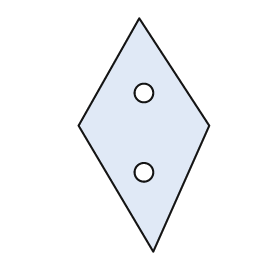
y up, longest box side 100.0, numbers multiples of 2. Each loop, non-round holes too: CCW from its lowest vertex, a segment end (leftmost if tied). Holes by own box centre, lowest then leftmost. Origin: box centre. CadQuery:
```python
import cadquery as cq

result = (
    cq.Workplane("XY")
    .moveTo(4.0, -50.0)
    .lineTo(28.0, 4.0)
    .lineTo(-2.0, 50.0)
    .lineTo(-28.0, 4.0)
    .close()
    .moveTo(0.0, -16.0)
    .circle(4.0)
    .moveTo(0.0, 18.0)
    .circle(4.0)
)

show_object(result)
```